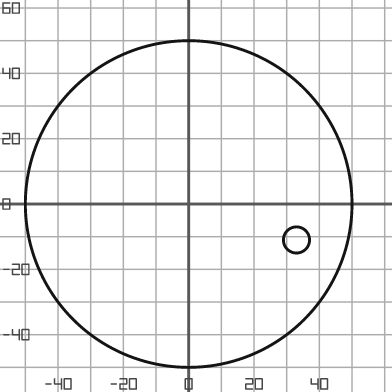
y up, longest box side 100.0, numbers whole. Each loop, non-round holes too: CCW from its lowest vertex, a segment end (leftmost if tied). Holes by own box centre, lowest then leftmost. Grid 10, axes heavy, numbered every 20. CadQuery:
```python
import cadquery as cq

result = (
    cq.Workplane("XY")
    .moveTo(0.0, 0.0)
    .circle(50.0)
    .moveTo(33.0, -11.0)
    .circle(4.0)
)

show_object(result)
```